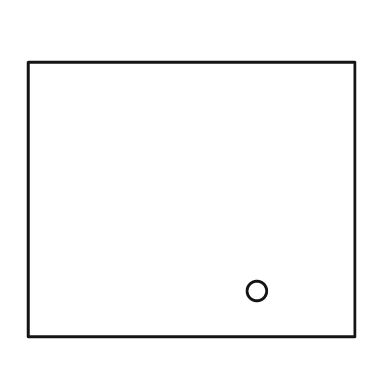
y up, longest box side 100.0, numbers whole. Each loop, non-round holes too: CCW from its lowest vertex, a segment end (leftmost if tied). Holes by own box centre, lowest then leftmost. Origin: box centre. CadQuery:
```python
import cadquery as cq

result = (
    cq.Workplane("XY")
    .moveTo(-50.0, -42.0)
    .lineTo(50.0, -42.0)
    .lineTo(50.0, 42.0)
    .lineTo(-50.0, 42.0)
    .close()
    .moveTo(20.0, -28.0)
    .circle(3.0)
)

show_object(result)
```